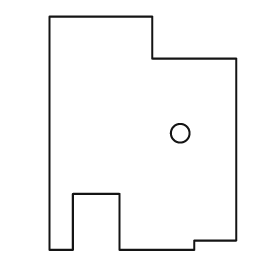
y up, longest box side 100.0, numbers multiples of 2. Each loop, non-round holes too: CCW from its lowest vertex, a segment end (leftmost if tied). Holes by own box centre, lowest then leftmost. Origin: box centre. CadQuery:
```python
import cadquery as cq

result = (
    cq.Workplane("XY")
    .moveTo(-40.0, -50.0)
    .lineTo(-30.0, -50.0)
    .lineTo(-30.0, -26.0)
    .lineTo(-10.0, -26.0)
    .lineTo(-10.0, -50.0)
    .lineTo(22.0, -50.0)
    .lineTo(22.0, -46.0)
    .lineTo(40.0, -46.0)
    .lineTo(40.0, 32.0)
    .lineTo(4.0, 32.0)
    .lineTo(4.0, 50.0)
    .lineTo(-40.0, 50.0)
    .close()
    .moveTo(16.0, 0.0)
    .circle(4.0)
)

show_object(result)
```